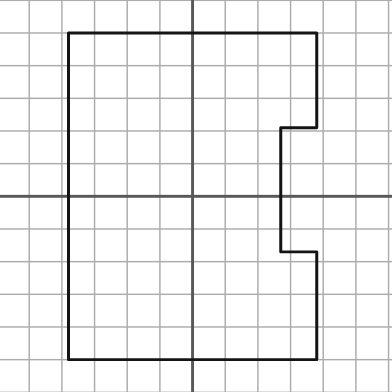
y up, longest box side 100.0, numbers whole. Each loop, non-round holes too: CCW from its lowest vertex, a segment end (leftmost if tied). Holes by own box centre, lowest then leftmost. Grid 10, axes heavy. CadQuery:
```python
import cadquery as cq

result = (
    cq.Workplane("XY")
    .moveTo(-38.0, -50.0)
    .lineTo(38.0, -50.0)
    .lineTo(38.0, -17.0)
    .lineTo(27.0, -17.0)
    .lineTo(27.0, 21.0)
    .lineTo(38.0, 21.0)
    .lineTo(38.0, 50.0)
    .lineTo(-38.0, 50.0)
    .close()
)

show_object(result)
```